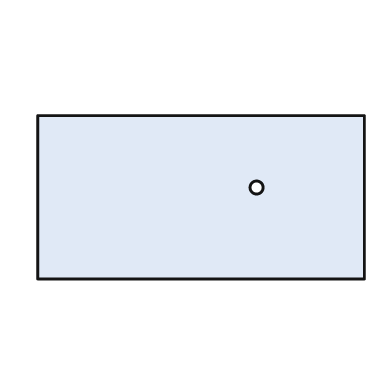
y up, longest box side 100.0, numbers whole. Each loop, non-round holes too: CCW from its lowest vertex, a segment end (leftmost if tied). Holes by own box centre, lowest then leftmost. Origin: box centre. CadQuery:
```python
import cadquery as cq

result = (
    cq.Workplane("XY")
    .moveTo(-50.0, -25.0)
    .lineTo(50.0, -25.0)
    .lineTo(50.0, 25.0)
    .lineTo(-50.0, 25.0)
    .close()
    .moveTo(17.0, 3.0)
    .circle(2.0)
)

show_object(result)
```